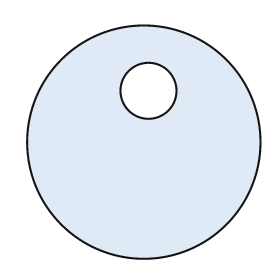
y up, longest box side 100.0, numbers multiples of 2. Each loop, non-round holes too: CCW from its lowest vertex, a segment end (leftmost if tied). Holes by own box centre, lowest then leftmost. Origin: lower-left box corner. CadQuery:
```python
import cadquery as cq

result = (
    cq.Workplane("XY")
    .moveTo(50.0, 50.0)
    .circle(50.0)
    .moveTo(52.0, 72.0)
    .circle(12.0)
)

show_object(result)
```